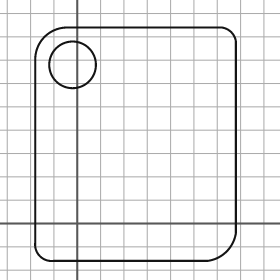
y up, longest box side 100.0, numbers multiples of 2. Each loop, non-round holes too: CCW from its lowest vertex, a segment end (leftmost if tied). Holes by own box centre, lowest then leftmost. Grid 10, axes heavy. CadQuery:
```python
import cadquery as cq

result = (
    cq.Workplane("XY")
    .moveTo(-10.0, -16.0)
    .lineTo(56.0, -16.0)
    .threePointArc((64.0, -12.0), (68.0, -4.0))
    .lineTo(68.0, 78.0)
    .threePointArc((66.0, 82.0), (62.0, 84.0))
    .lineTo(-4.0, 84.0)
    .threePointArc((-14.0, 80.0), (-18.0, 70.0))
    .lineTo(-18.0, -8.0)
    .threePointArc((-16.0, -14.0), (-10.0, -16.0))
    .close()
    .moveTo(-2.0, 68.0)
    .circle(10.0)
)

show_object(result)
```